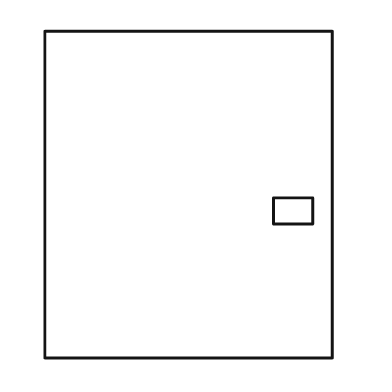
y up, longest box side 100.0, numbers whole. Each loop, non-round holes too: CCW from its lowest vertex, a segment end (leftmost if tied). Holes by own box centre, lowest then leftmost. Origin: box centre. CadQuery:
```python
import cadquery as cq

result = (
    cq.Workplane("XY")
    .moveTo(-44.0, -50.0)
    .lineTo(44.0, -50.0)
    .lineTo(44.0, 50.0)
    .lineTo(-44.0, 50.0)
    .close()
    .moveTo(26.0, -9.0)
    .lineTo(38.0, -9.0)
    .lineTo(38.0, -1.0)
    .lineTo(26.0, -1.0)
    .close()
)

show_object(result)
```